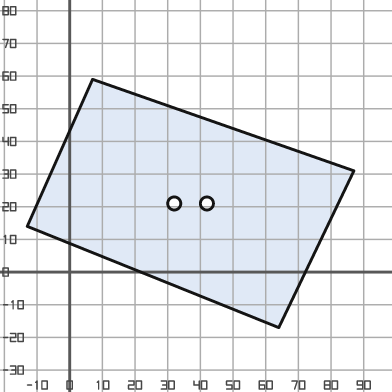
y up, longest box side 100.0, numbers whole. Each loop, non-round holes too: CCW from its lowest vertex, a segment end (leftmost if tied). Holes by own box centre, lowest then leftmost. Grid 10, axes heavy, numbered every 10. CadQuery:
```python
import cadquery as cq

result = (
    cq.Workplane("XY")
    .moveTo(64.0, -17.0)
    .lineTo(87.0, 31.0)
    .lineTo(7.0, 59.0)
    .lineTo(-13.0, 14.0)
    .close()
    .moveTo(32.0, 21.0)
    .circle(2.0)
    .moveTo(42.0, 21.0)
    .circle(2.0)
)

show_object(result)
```